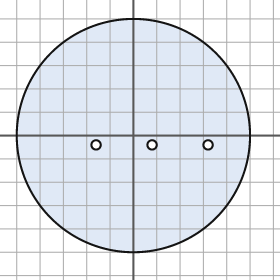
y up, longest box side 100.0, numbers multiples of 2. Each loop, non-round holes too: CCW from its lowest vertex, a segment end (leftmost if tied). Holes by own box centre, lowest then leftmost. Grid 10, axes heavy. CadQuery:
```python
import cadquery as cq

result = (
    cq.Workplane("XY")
    .moveTo(0.0, 0.0)
    .circle(50.0)
    .moveTo(-16.0, -4.0)
    .circle(2.0)
    .moveTo(8.0, -4.0)
    .circle(2.0)
    .moveTo(32.0, -4.0)
    .circle(2.0)
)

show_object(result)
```